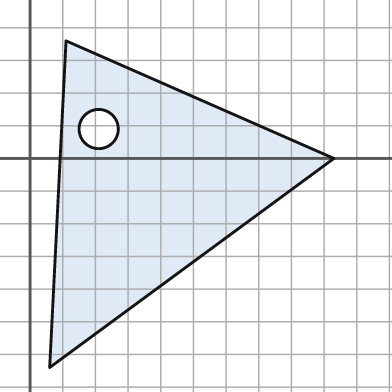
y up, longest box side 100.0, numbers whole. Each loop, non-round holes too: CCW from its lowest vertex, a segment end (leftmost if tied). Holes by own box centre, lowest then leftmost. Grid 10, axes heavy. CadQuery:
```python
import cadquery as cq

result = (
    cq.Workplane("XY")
    .moveTo(6.0, -64.0)
    .lineTo(93.0, 0.0)
    .lineTo(11.0, 36.0)
    .close()
    .moveTo(21.0, 9.0)
    .circle(6.0)
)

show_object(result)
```